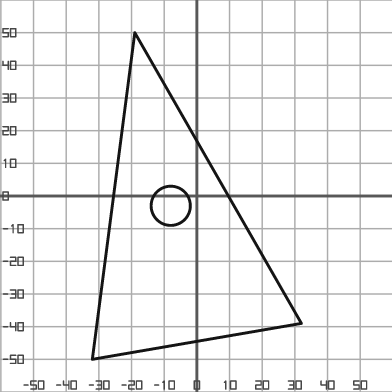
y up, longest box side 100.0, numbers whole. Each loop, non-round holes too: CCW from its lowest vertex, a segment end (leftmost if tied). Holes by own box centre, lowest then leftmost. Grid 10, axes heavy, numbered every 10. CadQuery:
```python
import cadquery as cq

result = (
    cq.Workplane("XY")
    .moveTo(-32.0, -50.0)
    .lineTo(32.0, -39.0)
    .lineTo(-19.0, 50.0)
    .close()
    .moveTo(-8.0, -3.0)
    .circle(6.0)
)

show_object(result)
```